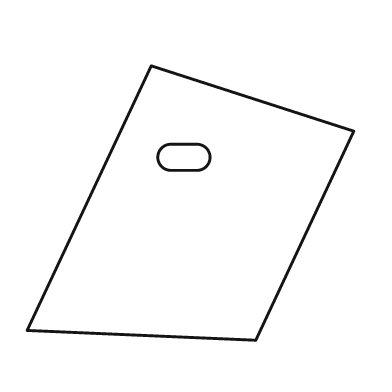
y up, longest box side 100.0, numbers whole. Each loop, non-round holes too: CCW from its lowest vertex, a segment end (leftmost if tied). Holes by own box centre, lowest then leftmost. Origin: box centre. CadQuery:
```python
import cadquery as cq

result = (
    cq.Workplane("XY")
    .moveTo(20.0, -42.0)
    .lineTo(50.0, 22.0)
    .lineTo(-12.0, 42.0)
    .lineTo(-50.0, -39.0)
    .close()
    .moveTo(-6.0, 10.0)
    .lineTo(2.0, 10.0)
    .threePointArc((6.0, 14.0), (2.0, 18.0))
    .lineTo(-6.0, 18.0)
    .threePointArc((-10.0, 14.0), (-6.0, 10.0))
    .close()
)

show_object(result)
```